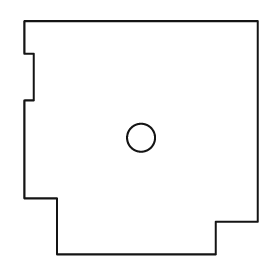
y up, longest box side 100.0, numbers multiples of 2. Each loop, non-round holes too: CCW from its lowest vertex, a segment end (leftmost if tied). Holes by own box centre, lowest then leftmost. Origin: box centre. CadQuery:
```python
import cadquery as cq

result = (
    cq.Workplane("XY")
    .moveTo(-36.0, -50.0)
    .lineTo(32.0, -50.0)
    .lineTo(32.0, -36.0)
    .lineTo(50.0, -36.0)
    .lineTo(50.0, 50.0)
    .lineTo(-50.0, 50.0)
    .lineTo(-50.0, 36.0)
    .lineTo(-46.0, 36.0)
    .lineTo(-46.0, 16.0)
    .lineTo(-50.0, 16.0)
    .lineTo(-50.0, -26.0)
    .lineTo(-36.0, -26.0)
    .close()
    .moveTo(0.0, 0.0)
    .circle(6.0)
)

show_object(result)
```